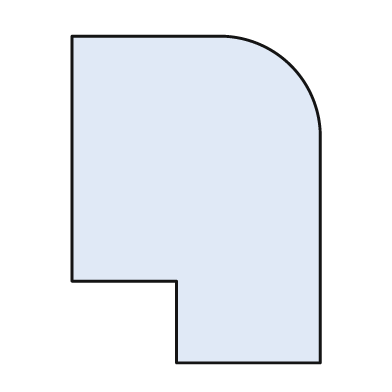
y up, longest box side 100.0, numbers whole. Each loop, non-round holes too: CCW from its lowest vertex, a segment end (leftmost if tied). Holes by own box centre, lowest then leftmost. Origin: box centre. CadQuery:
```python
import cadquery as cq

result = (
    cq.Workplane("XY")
    .moveTo(-6.0, -50.0)
    .lineTo(38.0, -50.0)
    .lineTo(38.0, 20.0)
    .threePointArc((29.0, 41.0), (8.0, 50.0))
    .lineTo(-38.0, 50.0)
    .lineTo(-38.0, -25.0)
    .lineTo(-6.0, -25.0)
    .close()
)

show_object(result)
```